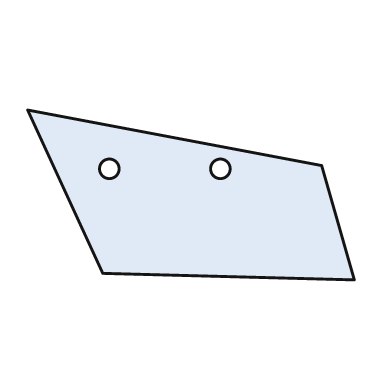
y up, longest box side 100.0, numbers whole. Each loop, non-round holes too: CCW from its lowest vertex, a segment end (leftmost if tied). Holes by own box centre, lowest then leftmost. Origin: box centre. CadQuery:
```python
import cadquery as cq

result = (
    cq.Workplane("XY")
    .moveTo(50.0, -26.0)
    .lineTo(40.0, 9.0)
    .lineTo(-50.0, 26.0)
    .lineTo(-27.0, -24.0)
    .close()
    .moveTo(-25.0, 8.0)
    .circle(3.0)
    .moveTo(9.0, 8.0)
    .circle(3.0)
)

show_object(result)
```